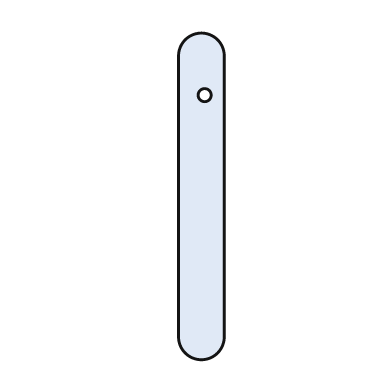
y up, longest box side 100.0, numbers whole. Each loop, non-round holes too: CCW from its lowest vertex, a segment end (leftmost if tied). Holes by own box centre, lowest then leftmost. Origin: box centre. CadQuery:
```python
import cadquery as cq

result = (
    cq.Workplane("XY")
    .moveTo(-7.0, -43.0)
    .threePointArc((0.0, -50.0), (7.0, -43.0))
    .lineTo(7.0, 43.0)
    .threePointArc((0.0, 50.0), (-7.0, 43.0))
    .close()
    .moveTo(1.0, 31.0)
    .circle(2.0)
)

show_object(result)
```